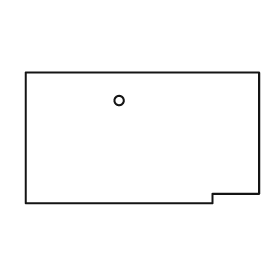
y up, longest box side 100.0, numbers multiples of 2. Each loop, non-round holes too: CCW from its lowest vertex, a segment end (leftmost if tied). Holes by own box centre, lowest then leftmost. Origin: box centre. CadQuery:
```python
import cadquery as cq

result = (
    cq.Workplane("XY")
    .moveTo(-50.0, -28.0)
    .lineTo(30.0, -28.0)
    .lineTo(30.0, -24.0)
    .lineTo(50.0, -24.0)
    .lineTo(50.0, 28.0)
    .lineTo(-50.0, 28.0)
    .close()
    .moveTo(-10.0, 16.0)
    .circle(2.0)
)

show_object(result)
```